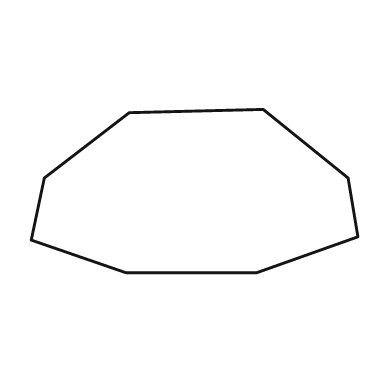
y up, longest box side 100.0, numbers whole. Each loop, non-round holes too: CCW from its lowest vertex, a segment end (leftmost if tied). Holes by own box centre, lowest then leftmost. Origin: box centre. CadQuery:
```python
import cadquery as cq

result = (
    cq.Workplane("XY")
    .moveTo(-21.0, -25.0)
    .lineTo(19.0, -25.0)
    .lineTo(50.0, -14.0)
    .lineTo(47.0, 4.0)
    .lineTo(21.0, 25.0)
    .lineTo(-20.0, 24.0)
    .lineTo(-46.0, 4.0)
    .lineTo(-50.0, -15.0)
    .close()
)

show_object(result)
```